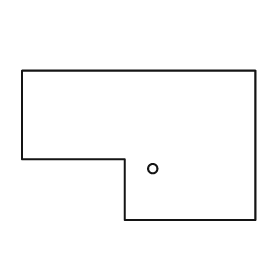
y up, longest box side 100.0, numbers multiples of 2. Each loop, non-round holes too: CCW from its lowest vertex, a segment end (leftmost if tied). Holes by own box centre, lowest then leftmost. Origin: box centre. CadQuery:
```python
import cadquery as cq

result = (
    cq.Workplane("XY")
    .moveTo(-6.0, -32.0)
    .lineTo(50.0, -32.0)
    .lineTo(50.0, 32.0)
    .lineTo(-50.0, 32.0)
    .lineTo(-50.0, -6.0)
    .lineTo(-6.0, -6.0)
    .close()
    .moveTo(6.0, -10.0)
    .circle(2.0)
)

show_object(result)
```